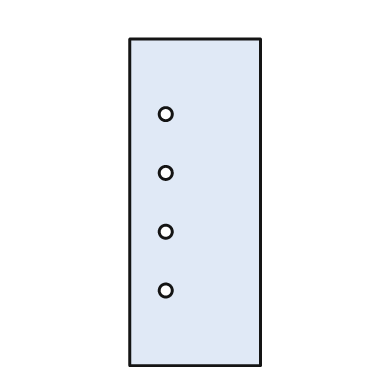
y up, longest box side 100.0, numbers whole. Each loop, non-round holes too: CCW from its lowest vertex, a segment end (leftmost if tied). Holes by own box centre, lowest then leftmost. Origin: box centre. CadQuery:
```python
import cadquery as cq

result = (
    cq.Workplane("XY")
    .moveTo(-20.0, -50.0)
    .lineTo(20.0, -50.0)
    .lineTo(20.0, 50.0)
    .lineTo(-20.0, 50.0)
    .close()
    .moveTo(-9.0, -27.0)
    .circle(2.0)
    .moveTo(-9.0, -9.0)
    .circle(2.0)
    .moveTo(-9.0, 9.0)
    .circle(2.0)
    .moveTo(-9.0, 27.0)
    .circle(2.0)
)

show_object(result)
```